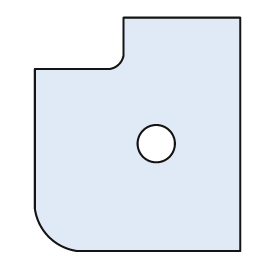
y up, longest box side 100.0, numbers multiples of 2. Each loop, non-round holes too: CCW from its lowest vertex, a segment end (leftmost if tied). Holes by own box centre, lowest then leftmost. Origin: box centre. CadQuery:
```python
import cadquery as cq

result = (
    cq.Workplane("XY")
    .moveTo(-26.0, -50.0)
    .lineTo(44.0, -50.0)
    .lineTo(44.0, 50.0)
    .lineTo(-6.0, 50.0)
    .lineTo(-6.0, 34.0)
    .threePointArc((-8.0, 30.0), (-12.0, 28.0))
    .lineTo(-44.0, 28.0)
    .lineTo(-44.0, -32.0)
    .threePointArc((-38.0, -44.0), (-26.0, -50.0))
    .close()
    .moveTo(8.0, -4.0)
    .circle(8.0)
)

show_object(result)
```